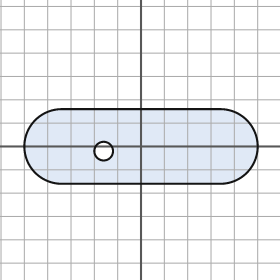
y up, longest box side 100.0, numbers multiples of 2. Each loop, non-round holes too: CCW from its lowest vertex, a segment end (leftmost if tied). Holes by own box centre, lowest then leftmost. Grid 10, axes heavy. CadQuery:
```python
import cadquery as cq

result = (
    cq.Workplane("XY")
    .moveTo(-34.0, -16.0)
    .lineTo(34.0, -16.0)
    .threePointArc((50.0, 0.0), (34.0, 16.0))
    .lineTo(-34.0, 16.0)
    .threePointArc((-50.0, 0.0), (-34.0, -16.0))
    .close()
    .moveTo(-16.0, -2.0)
    .circle(4.0)
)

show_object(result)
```